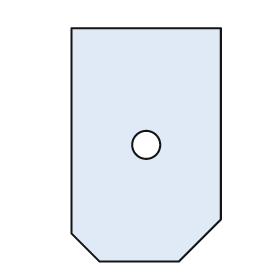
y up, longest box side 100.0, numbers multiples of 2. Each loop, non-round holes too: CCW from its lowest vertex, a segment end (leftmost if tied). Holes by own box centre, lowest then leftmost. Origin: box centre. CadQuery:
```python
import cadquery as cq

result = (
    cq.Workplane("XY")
    .moveTo(-20.0, -50.0)
    .lineTo(14.0, -50.0)
    .lineTo(32.0, -32.0)
    .lineTo(32.0, 50.0)
    .lineTo(-32.0, 50.0)
    .lineTo(-32.0, -38.0)
    .close()
    .moveTo(0.0, 0.0)
    .circle(6.0)
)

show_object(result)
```